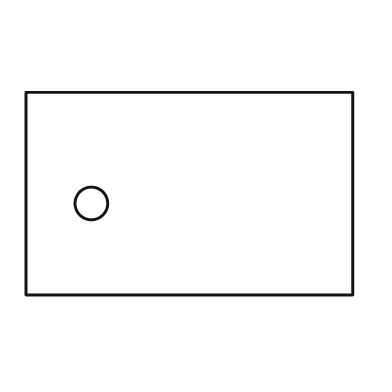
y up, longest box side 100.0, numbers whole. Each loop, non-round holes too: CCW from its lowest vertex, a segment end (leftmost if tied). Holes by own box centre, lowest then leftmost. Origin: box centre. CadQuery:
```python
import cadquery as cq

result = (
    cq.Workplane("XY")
    .moveTo(-50.0, -31.0)
    .lineTo(50.0, -31.0)
    .lineTo(50.0, 31.0)
    .lineTo(-50.0, 31.0)
    .close()
    .moveTo(-30.0, -3.0)
    .circle(5.0)
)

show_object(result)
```